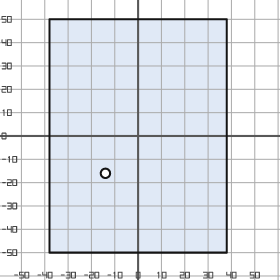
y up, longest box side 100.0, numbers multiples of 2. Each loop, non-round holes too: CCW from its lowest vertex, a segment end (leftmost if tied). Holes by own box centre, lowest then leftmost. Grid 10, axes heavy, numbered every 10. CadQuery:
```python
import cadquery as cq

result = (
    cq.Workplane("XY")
    .moveTo(-38.0, -50.0)
    .lineTo(38.0, -50.0)
    .lineTo(38.0, 50.0)
    .lineTo(-38.0, 50.0)
    .close()
    .moveTo(-14.0, -16.0)
    .circle(2.0)
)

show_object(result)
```